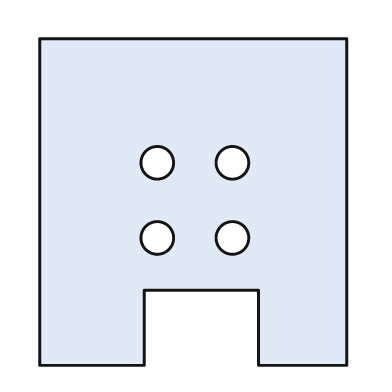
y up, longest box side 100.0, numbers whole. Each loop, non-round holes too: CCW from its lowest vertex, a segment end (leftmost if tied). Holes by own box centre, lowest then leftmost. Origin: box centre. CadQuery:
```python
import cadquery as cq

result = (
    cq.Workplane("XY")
    .moveTo(-47.0, -50.0)
    .lineTo(-15.0, -50.0)
    .lineTo(-15.0, -27.0)
    .lineTo(20.0, -27.0)
    .lineTo(20.0, -50.0)
    .lineTo(47.0, -50.0)
    .lineTo(47.0, 50.0)
    .lineTo(-47.0, 50.0)
    .close()
    .moveTo(-11.0, -11.0)
    .circle(5.0)
    .moveTo(12.0, -11.0)
    .circle(5.0)
    .moveTo(-11.0, 12.0)
    .circle(5.0)
    .moveTo(12.0, 12.0)
    .circle(5.0)
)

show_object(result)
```